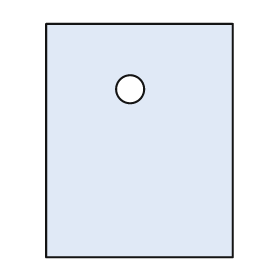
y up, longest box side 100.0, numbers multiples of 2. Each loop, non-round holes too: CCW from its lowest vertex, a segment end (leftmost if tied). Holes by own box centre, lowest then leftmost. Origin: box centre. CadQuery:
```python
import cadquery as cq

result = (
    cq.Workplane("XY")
    .moveTo(-40.0, -50.0)
    .lineTo(40.0, -50.0)
    .lineTo(40.0, 50.0)
    .lineTo(-40.0, 50.0)
    .close()
    .moveTo(-4.0, 22.0)
    .circle(6.0)
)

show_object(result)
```